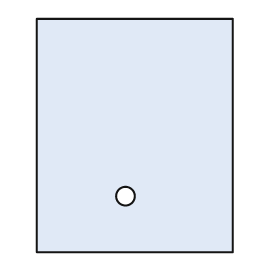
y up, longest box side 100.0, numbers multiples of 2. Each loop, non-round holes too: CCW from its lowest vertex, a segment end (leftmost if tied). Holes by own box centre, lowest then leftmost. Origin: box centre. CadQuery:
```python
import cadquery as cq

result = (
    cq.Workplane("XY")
    .moveTo(-42.0, -50.0)
    .lineTo(42.0, -50.0)
    .lineTo(42.0, 50.0)
    .lineTo(-42.0, 50.0)
    .close()
    .moveTo(-4.0, -26.0)
    .circle(4.0)
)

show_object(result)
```